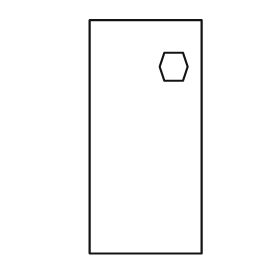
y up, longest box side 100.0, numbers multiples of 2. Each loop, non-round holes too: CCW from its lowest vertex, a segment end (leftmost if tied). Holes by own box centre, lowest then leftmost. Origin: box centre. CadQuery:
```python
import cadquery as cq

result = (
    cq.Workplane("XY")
    .moveTo(-24.0, -50.0)
    .lineTo(24.0, -50.0)
    .lineTo(24.0, 50.0)
    .lineTo(-24.0, 50.0)
    .close()
    .moveTo(8.0, 24.0)
    .lineTo(16.0, 24.0)
    .lineTo(18.0, 30.0)
    .lineTo(16.0, 36.0)
    .lineTo(8.0, 36.0)
    .lineTo(6.0, 30.0)
    .close()
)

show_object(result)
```